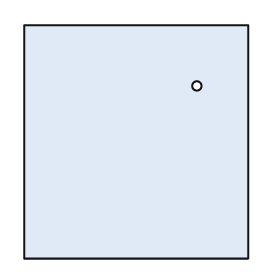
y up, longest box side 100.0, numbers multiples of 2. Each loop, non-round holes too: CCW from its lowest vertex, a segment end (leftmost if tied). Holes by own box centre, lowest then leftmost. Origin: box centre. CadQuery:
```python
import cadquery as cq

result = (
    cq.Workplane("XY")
    .moveTo(-48.0, -50.0)
    .lineTo(48.0, -50.0)
    .lineTo(48.0, 50.0)
    .lineTo(-48.0, 50.0)
    .close()
    .moveTo(26.0, 24.0)
    .circle(2.0)
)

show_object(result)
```